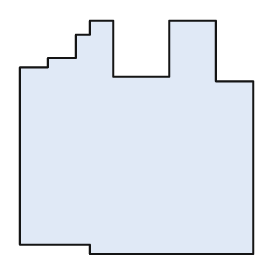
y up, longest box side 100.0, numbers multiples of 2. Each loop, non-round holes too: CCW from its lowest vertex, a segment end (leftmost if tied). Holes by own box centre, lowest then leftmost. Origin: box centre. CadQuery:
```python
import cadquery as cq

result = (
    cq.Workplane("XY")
    .moveTo(-20.0, -50.0)
    .lineTo(50.0, -50.0)
    .lineTo(50.0, 24.0)
    .lineTo(34.0, 24.0)
    .lineTo(34.0, 50.0)
    .lineTo(14.0, 50.0)
    .lineTo(14.0, 26.0)
    .lineTo(-10.0, 26.0)
    .lineTo(-10.0, 50.0)
    .lineTo(-20.0, 50.0)
    .lineTo(-20.0, 44.0)
    .lineTo(-26.0, 44.0)
    .lineTo(-26.0, 34.0)
    .lineTo(-38.0, 34.0)
    .lineTo(-38.0, 30.0)
    .lineTo(-50.0, 30.0)
    .lineTo(-50.0, -46.0)
    .lineTo(-20.0, -46.0)
    .close()
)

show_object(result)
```